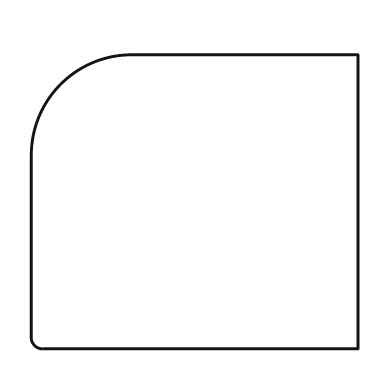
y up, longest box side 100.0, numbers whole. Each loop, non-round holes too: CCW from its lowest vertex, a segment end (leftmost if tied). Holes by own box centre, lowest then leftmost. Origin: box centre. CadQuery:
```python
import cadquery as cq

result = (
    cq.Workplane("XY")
    .moveTo(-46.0, -45.0)
    .lineTo(50.0, -45.0)
    .lineTo(50.0, 45.0)
    .lineTo(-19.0, 45.0)
    .threePointArc((-41.0, 36.0), (-50.0, 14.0))
    .lineTo(-50.0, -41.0)
    .threePointArc((-49.0, -44.0), (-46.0, -45.0))
    .close()
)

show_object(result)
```